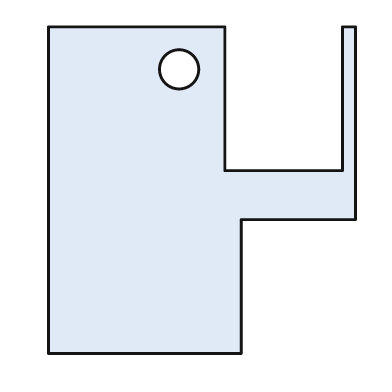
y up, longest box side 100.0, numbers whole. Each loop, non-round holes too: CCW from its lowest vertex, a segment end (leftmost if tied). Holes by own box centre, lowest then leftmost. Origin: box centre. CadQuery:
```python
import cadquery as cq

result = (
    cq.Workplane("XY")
    .moveTo(-47.0, -50.0)
    .lineTo(12.0, -50.0)
    .lineTo(12.0, -9.0)
    .lineTo(47.0, -9.0)
    .lineTo(47.0, 50.0)
    .lineTo(43.0, 50.0)
    .lineTo(43.0, 6.0)
    .lineTo(7.0, 6.0)
    .lineTo(7.0, 50.0)
    .lineTo(-47.0, 50.0)
    .close()
    .moveTo(-7.0, 37.0)
    .circle(6.0)
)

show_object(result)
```